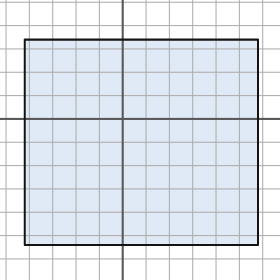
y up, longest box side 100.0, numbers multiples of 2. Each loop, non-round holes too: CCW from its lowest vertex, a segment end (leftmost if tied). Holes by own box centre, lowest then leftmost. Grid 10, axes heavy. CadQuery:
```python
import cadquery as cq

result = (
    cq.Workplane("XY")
    .moveTo(-42.0, -54.0)
    .lineTo(58.0, -54.0)
    .lineTo(58.0, 34.0)
    .lineTo(-42.0, 34.0)
    .close()
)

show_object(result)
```